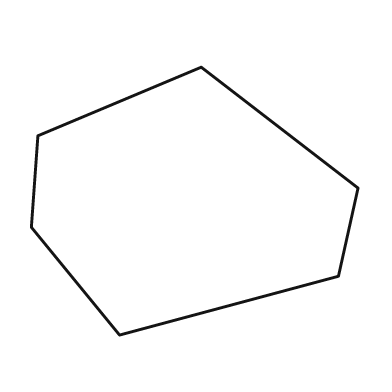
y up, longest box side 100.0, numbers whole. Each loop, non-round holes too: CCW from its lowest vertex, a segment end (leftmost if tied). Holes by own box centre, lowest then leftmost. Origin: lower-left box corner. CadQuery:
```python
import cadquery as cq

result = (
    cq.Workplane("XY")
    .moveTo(27.0, 0.0)
    .lineTo(94.0, 18.0)
    .lineTo(100.0, 45.0)
    .lineTo(52.0, 82.0)
    .lineTo(2.0, 61.0)
    .lineTo(0.0, 33.0)
    .close()
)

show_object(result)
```